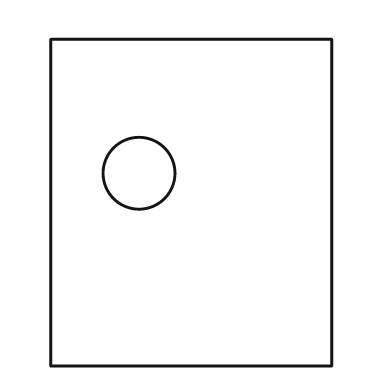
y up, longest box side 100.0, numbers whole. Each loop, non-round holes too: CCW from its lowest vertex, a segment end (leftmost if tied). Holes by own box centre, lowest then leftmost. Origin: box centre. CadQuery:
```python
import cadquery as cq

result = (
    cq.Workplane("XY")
    .moveTo(-43.0, -50.0)
    .lineTo(43.0, -50.0)
    .lineTo(43.0, 50.0)
    .lineTo(-43.0, 50.0)
    .close()
    .moveTo(-16.0, 9.0)
    .circle(11.0)
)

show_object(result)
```